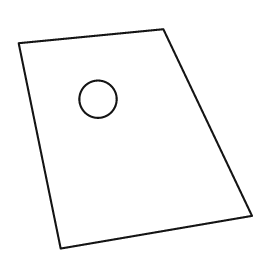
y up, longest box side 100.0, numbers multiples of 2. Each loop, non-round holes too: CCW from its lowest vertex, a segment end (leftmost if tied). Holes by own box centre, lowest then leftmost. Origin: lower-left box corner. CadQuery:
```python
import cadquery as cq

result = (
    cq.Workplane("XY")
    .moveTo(18.0, 0.0)
    .lineTo(100.0, 14.0)
    .lineTo(62.0, 94.0)
    .lineTo(0.0, 88.0)
    .close()
    .moveTo(34.0, 64.0)
    .circle(8.0)
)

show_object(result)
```